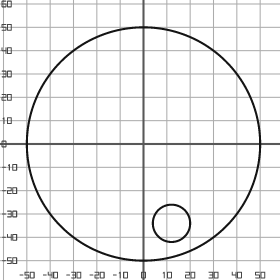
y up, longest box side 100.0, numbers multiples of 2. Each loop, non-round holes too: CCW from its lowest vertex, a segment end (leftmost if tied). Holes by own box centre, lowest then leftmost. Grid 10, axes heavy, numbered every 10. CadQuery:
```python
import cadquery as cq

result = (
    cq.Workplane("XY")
    .moveTo(0.0, 0.0)
    .circle(50.0)
    .moveTo(12.0, -34.0)
    .circle(8.0)
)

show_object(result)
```